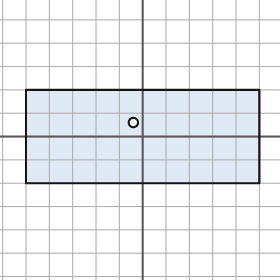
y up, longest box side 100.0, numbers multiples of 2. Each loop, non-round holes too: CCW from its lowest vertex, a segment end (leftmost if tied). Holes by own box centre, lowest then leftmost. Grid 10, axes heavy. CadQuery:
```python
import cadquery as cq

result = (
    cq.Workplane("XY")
    .moveTo(-50.0, -20.0)
    .lineTo(50.0, -20.0)
    .lineTo(50.0, 20.0)
    .lineTo(-50.0, 20.0)
    .close()
    .moveTo(-4.0, 6.0)
    .circle(2.0)
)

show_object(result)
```